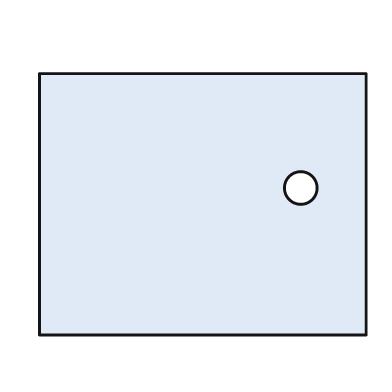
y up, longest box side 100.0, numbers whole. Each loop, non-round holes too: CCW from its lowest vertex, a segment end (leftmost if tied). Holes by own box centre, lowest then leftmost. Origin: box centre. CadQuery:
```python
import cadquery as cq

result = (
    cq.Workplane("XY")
    .moveTo(-50.0, -40.0)
    .lineTo(50.0, -40.0)
    .lineTo(50.0, 40.0)
    .lineTo(-50.0, 40.0)
    .close()
    .moveTo(30.0, 5.0)
    .circle(5.0)
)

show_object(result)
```